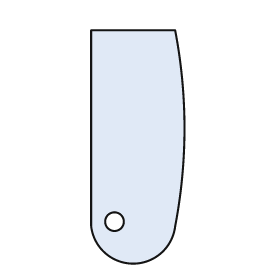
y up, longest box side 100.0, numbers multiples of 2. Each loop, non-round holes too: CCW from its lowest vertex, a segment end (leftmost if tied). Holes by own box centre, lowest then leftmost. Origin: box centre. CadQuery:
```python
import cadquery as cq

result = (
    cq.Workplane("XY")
    .moveTo(-20.0, -34.0)
    .threePointArc((-2.0, -50.0), (16.0, -34.0))
    .threePointArc((20.0, 8.0), (16.0, 50.0))
    .lineTo(-20.0, 50.0)
    .close()
    .moveTo(-10.0, -32.0)
    .circle(4.0)
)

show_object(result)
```